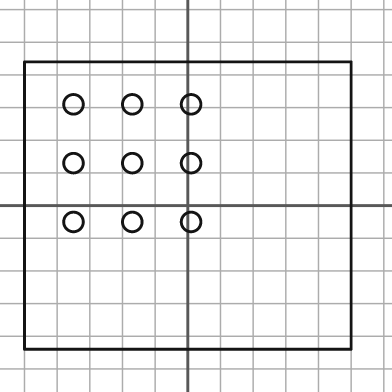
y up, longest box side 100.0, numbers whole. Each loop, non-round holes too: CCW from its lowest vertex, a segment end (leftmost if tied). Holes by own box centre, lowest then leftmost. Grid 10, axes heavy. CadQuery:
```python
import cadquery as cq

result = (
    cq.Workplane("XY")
    .moveTo(-50.0, -44.0)
    .lineTo(50.0, -44.0)
    .lineTo(50.0, 44.0)
    .lineTo(-50.0, 44.0)
    .close()
    .moveTo(-35.0, -5.0)
    .circle(3.0)
    .moveTo(-17.0, -5.0)
    .circle(3.0)
    .moveTo(1.0, -5.0)
    .circle(3.0)
    .moveTo(-35.0, 13.0)
    .circle(3.0)
    .moveTo(-17.0, 13.0)
    .circle(3.0)
    .moveTo(1.0, 13.0)
    .circle(3.0)
    .moveTo(-35.0, 31.0)
    .circle(3.0)
    .moveTo(-17.0, 31.0)
    .circle(3.0)
    .moveTo(1.0, 31.0)
    .circle(3.0)
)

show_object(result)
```